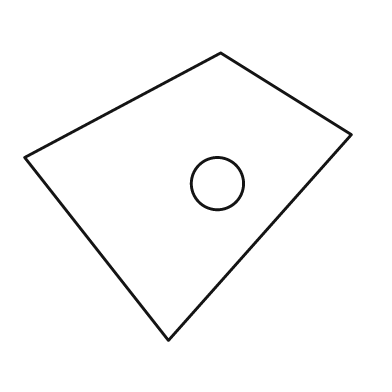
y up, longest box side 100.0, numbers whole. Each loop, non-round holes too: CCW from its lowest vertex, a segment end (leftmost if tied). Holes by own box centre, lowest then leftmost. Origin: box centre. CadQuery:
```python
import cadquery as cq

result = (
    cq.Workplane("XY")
    .moveTo(-6.0, -44.0)
    .lineTo(50.0, 19.0)
    .lineTo(10.0, 44.0)
    .lineTo(-50.0, 12.0)
    .close()
    .moveTo(9.0, 4.0)
    .circle(8.0)
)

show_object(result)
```